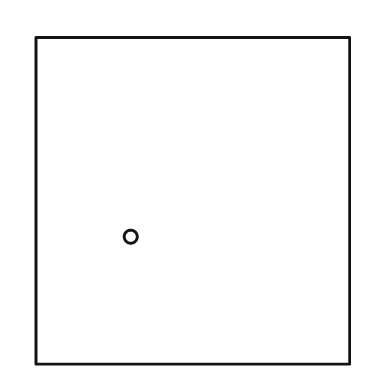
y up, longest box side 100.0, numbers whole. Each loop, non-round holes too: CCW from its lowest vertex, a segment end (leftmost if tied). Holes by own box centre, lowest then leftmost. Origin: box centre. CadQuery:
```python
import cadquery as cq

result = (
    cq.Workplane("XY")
    .moveTo(-48.0, -50.0)
    .lineTo(48.0, -50.0)
    .lineTo(48.0, 50.0)
    .lineTo(-48.0, 50.0)
    .close()
    .moveTo(-19.0, -11.0)
    .circle(2.0)
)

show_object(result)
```